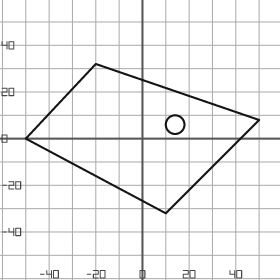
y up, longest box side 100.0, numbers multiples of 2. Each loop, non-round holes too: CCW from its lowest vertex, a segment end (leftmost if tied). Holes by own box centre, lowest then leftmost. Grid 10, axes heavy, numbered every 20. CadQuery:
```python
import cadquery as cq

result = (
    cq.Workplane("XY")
    .moveTo(10.0, -32.0)
    .lineTo(50.0, 8.0)
    .lineTo(-20.0, 32.0)
    .lineTo(-50.0, 0.0)
    .close()
    .moveTo(14.0, 6.0)
    .circle(4.0)
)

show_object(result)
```